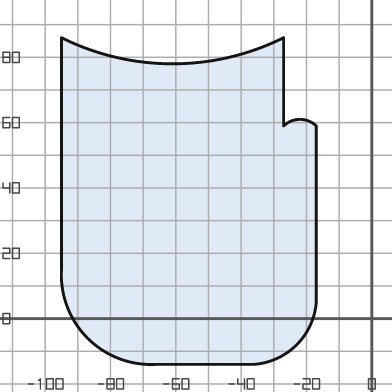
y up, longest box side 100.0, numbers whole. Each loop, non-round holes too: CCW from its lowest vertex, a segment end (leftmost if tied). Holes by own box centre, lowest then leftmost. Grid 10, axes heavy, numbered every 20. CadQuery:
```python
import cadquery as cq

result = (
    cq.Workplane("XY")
    .moveTo(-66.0, -14.0)
    .lineTo(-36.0, -14.0)
    .threePointArc((-23.0, -8.0), (-17.0, 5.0))
    .lineTo(-17.0, 59.0)
    .threePointArc((-22.0, 61.0), (-27.0, 59.0))
    .lineTo(-27.0, 86.0)
    .threePointArc((-61.0, 78.0), (-95.0, 86.0))
    .lineTo(-95.0, 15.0)
    .threePointArc((-87.0, -6.0), (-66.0, -14.0))
    .close()
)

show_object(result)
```